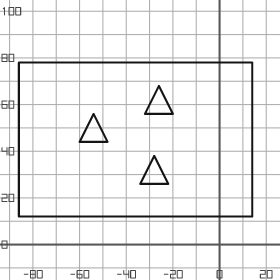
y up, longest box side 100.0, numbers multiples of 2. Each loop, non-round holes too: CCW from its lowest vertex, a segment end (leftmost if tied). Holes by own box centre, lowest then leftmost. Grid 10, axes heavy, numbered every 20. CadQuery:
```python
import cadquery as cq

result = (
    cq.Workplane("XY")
    .moveTo(-86.0, 12.0)
    .lineTo(14.0, 12.0)
    .lineTo(14.0, 78.0)
    .lineTo(-86.0, 78.0)
    .close()
    .moveTo(-34.0, 26.0)
    .lineTo(-22.0, 26.0)
    .lineTo(-28.0, 38.0)
    .close()
    .moveTo(-60.0, 44.0)
    .lineTo(-48.0, 44.0)
    .lineTo(-54.0, 56.0)
    .close()
    .moveTo(-32.0, 56.0)
    .lineTo(-20.0, 56.0)
    .lineTo(-26.0, 68.0)
    .close()
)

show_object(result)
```